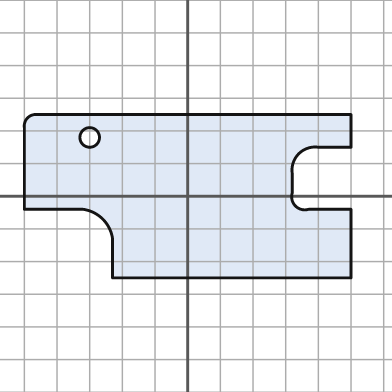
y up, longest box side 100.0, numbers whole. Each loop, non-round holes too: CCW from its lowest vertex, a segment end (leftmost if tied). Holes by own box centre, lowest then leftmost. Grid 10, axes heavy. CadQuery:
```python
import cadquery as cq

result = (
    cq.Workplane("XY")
    .moveTo(-23.0, -25.0)
    .lineTo(50.0, -25.0)
    .lineTo(50.0, -4.0)
    .lineTo(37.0, -4.0)
    .threePointArc((33.0, -3.0), (32.0, 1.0))
    .lineTo(32.0, 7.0)
    .threePointArc((34.0, 13.0), (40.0, 15.0))
    .lineTo(50.0, 15.0)
    .lineTo(50.0, 25.0)
    .lineTo(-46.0, 25.0)
    .threePointArc((-49.0, 24.0), (-50.0, 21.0))
    .lineTo(-50.0, -4.0)
    .lineTo(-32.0, -4.0)
    .threePointArc((-26.0, -7.0), (-23.0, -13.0))
    .close()
    .moveTo(-30.0, 18.0)
    .circle(3.0)
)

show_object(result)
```